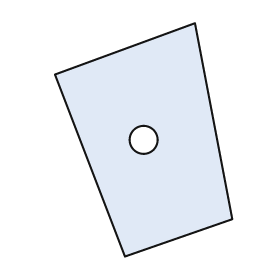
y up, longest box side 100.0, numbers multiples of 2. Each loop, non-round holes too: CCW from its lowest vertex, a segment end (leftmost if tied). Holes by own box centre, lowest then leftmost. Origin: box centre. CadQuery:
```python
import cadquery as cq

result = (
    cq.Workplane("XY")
    .moveTo(-8.0, -50.0)
    .lineTo(38.0, -34.0)
    .lineTo(22.0, 50.0)
    .lineTo(-38.0, 28.0)
    .close()
    .moveTo(0.0, 0.0)
    .circle(6.0)
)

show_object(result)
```